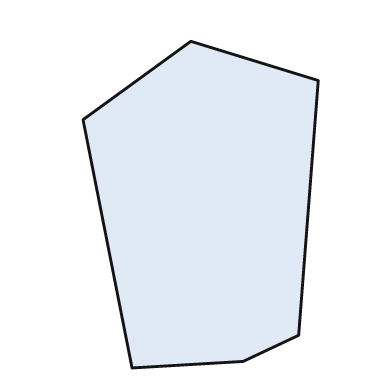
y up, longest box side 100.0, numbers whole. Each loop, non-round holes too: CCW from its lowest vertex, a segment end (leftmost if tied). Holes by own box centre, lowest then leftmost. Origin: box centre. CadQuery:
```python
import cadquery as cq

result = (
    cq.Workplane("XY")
    .moveTo(-21.0, -50.0)
    .lineTo(13.0, -48.0)
    .lineTo(30.0, -40.0)
    .lineTo(36.0, 38.0)
    .lineTo(-3.0, 50.0)
    .lineTo(-36.0, 26.0)
    .close()
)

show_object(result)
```